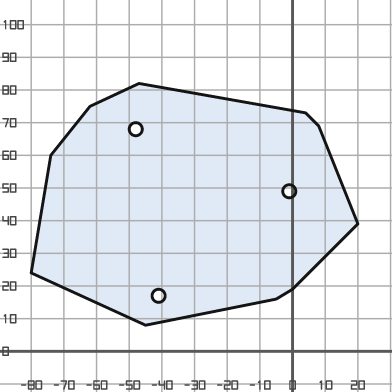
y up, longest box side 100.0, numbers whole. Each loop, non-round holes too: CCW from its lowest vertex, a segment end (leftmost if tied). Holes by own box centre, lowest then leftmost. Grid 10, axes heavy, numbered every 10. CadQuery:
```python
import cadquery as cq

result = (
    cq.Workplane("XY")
    .moveTo(-45.0, 8.0)
    .lineTo(-5.0, 16.0)
    .lineTo(0.0, 19.0)
    .lineTo(20.0, 39.0)
    .lineTo(8.0, 69.0)
    .lineTo(4.0, 73.0)
    .lineTo(-47.0, 82.0)
    .lineTo(-62.0, 75.0)
    .lineTo(-74.0, 60.0)
    .lineTo(-80.0, 24.0)
    .close()
    .moveTo(-41.0, 17.0)
    .circle(2.0)
    .moveTo(-1.0, 49.0)
    .circle(2.0)
    .moveTo(-48.0, 68.0)
    .circle(2.0)
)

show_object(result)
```